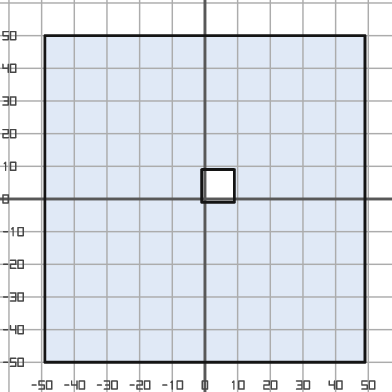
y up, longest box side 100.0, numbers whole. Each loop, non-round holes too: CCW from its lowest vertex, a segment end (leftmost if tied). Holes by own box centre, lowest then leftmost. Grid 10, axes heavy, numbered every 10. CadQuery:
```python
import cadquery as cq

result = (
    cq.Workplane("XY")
    .moveTo(-49.0, -50.0)
    .lineTo(49.0, -50.0)
    .lineTo(49.0, 50.0)
    .lineTo(-49.0, 50.0)
    .close()
    .moveTo(-1.0, -1.0)
    .lineTo(9.0, -1.0)
    .lineTo(9.0, 9.0)
    .lineTo(-1.0, 9.0)
    .close()
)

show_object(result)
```